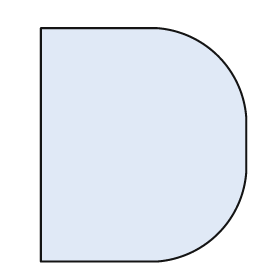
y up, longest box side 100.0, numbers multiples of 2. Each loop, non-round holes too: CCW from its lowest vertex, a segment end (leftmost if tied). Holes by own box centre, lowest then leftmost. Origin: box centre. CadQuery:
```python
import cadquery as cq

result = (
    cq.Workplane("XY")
    .moveTo(-44.0, -50.0)
    .lineTo(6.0, -50.0)
    .threePointArc((32.0, -38.0), (44.0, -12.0))
    .lineTo(44.0, 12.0)
    .threePointArc((32.0, 38.0), (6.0, 50.0))
    .lineTo(-44.0, 50.0)
    .close()
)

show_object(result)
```